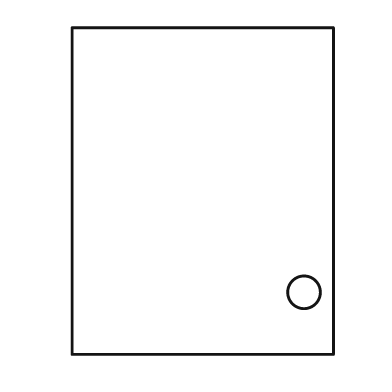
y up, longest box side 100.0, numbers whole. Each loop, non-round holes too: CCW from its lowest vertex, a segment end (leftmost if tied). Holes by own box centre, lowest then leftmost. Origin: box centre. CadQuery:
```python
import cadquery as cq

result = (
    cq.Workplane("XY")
    .moveTo(-40.0, -50.0)
    .lineTo(40.0, -50.0)
    .lineTo(40.0, 50.0)
    .lineTo(-40.0, 50.0)
    .close()
    .moveTo(31.0, -31.0)
    .circle(5.0)
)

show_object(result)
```